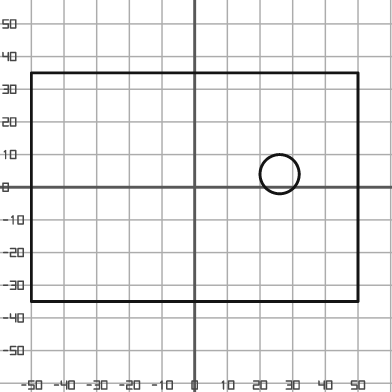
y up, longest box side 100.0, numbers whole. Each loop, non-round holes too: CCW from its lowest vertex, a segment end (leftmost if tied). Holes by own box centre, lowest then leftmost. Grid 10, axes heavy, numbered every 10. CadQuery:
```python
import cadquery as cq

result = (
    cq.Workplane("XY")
    .moveTo(-50.0, -35.0)
    .lineTo(50.0, -35.0)
    .lineTo(50.0, 35.0)
    .lineTo(-50.0, 35.0)
    .close()
    .moveTo(26.0, 4.0)
    .circle(6.0)
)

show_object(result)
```